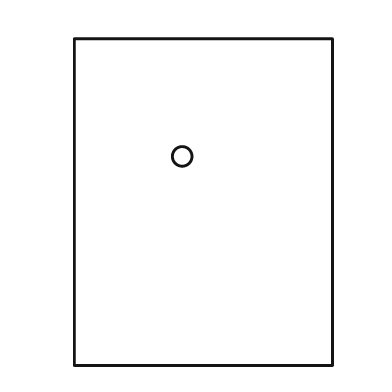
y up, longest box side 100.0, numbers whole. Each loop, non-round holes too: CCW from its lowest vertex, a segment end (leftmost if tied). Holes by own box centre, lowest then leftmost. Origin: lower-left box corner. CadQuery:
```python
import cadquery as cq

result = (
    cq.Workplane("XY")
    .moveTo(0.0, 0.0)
    .lineTo(79.0, 0.0)
    .lineTo(79.0, 100.0)
    .lineTo(0.0, 100.0)
    .close()
    .moveTo(33.0, 64.0)
    .circle(3.0)
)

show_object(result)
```